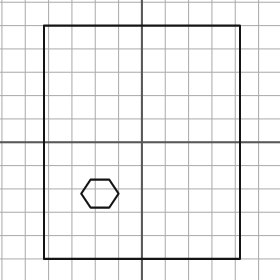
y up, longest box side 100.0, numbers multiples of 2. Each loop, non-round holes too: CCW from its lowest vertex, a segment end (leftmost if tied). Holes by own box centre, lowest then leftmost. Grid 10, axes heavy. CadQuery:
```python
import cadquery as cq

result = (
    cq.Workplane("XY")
    .moveTo(-42.0, -50.0)
    .lineTo(42.0, -50.0)
    .lineTo(42.0, 50.0)
    .lineTo(-42.0, 50.0)
    .close()
    .moveTo(-22.0, -28.0)
    .lineTo(-14.0, -28.0)
    .lineTo(-10.0, -22.0)
    .lineTo(-14.0, -16.0)
    .lineTo(-22.0, -16.0)
    .lineTo(-26.0, -22.0)
    .close()
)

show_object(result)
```